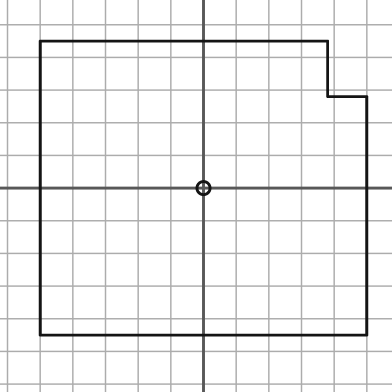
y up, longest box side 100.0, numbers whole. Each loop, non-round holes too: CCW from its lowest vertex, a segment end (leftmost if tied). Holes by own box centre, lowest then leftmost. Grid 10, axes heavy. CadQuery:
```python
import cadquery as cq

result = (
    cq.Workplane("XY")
    .moveTo(-50.0, -45.0)
    .lineTo(50.0, -45.0)
    .lineTo(50.0, 28.0)
    .lineTo(38.0, 28.0)
    .lineTo(38.0, 45.0)
    .lineTo(-50.0, 45.0)
    .close()
    .moveTo(0.0, 0.0)
    .circle(2.0)
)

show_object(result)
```